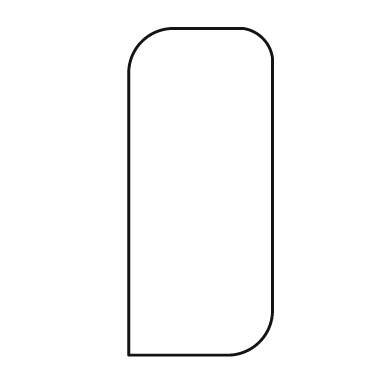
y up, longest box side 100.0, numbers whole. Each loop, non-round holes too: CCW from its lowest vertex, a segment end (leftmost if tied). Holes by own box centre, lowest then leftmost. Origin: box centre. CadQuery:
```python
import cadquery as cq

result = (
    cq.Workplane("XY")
    .moveTo(-22.0, -50.0)
    .lineTo(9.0, -50.0)
    .threePointArc((18.0, -46.0), (22.0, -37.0))
    .lineTo(22.0, 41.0)
    .threePointArc((19.0, 47.0), (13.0, 50.0))
    .lineTo(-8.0, 50.0)
    .threePointArc((-18.0, 46.0), (-22.0, 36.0))
    .close()
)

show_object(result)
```